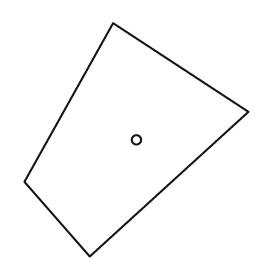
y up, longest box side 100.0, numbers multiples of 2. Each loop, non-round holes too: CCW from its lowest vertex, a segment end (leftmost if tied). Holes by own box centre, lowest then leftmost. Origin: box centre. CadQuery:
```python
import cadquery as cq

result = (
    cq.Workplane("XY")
    .moveTo(-20.0, -50.0)
    .lineTo(48.0, 12.0)
    .lineTo(-10.0, 50.0)
    .lineTo(-48.0, -18.0)
    .close()
    .moveTo(0.0, 0.0)
    .circle(2.0)
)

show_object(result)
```